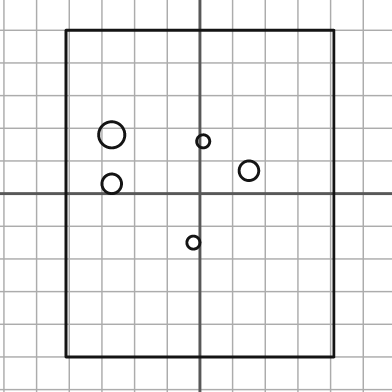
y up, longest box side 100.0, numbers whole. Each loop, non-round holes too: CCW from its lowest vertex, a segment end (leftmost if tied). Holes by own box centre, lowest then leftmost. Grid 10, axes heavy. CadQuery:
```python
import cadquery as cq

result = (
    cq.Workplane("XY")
    .moveTo(-41.0, -50.0)
    .lineTo(41.0, -50.0)
    .lineTo(41.0, 50.0)
    .lineTo(-41.0, 50.0)
    .close()
    .moveTo(-2.0, -15.0)
    .circle(2.0)
    .moveTo(-27.0, 3.0)
    .circle(3.0)
    .moveTo(15.0, 7.0)
    .circle(3.0)
    .moveTo(1.0, 16.0)
    .circle(2.0)
    .moveTo(-27.0, 18.0)
    .circle(4.0)
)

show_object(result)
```